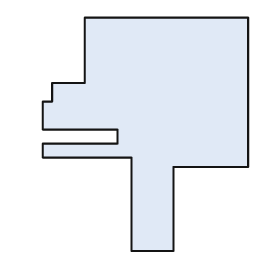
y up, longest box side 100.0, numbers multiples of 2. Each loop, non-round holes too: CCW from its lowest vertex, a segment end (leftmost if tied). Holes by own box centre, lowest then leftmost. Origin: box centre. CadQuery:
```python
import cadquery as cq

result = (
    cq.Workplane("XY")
    .moveTo(-6.0, -50.0)
    .lineTo(12.0, -50.0)
    .lineTo(12.0, -14.0)
    .lineTo(44.0, -14.0)
    .lineTo(44.0, 50.0)
    .lineTo(-26.0, 50.0)
    .lineTo(-26.0, 22.0)
    .lineTo(-40.0, 22.0)
    .lineTo(-40.0, 14.0)
    .lineTo(-44.0, 14.0)
    .lineTo(-44.0, 2.0)
    .lineTo(-12.0, 2.0)
    .lineTo(-12.0, -4.0)
    .lineTo(-44.0, -4.0)
    .lineTo(-44.0, -10.0)
    .lineTo(-6.0, -10.0)
    .close()
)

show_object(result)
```